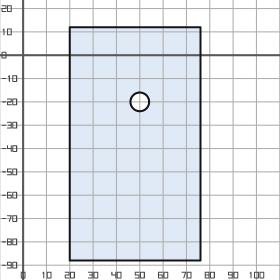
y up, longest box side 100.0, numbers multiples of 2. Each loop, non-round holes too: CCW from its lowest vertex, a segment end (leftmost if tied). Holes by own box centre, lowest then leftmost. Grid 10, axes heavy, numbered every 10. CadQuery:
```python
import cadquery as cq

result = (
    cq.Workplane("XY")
    .moveTo(20.0, -88.0)
    .lineTo(76.0, -88.0)
    .lineTo(76.0, 12.0)
    .lineTo(20.0, 12.0)
    .close()
    .moveTo(50.0, -20.0)
    .circle(4.0)
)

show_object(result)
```